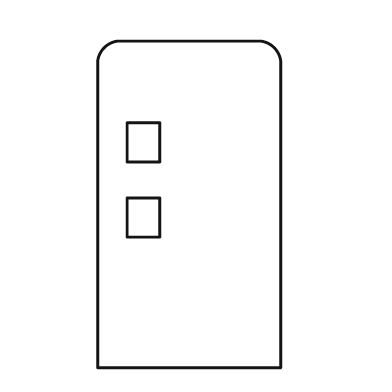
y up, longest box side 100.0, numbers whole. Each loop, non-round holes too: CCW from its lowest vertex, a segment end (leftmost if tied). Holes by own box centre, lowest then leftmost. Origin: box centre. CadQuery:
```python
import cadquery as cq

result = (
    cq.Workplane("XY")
    .moveTo(-28.0, -50.0)
    .lineTo(28.0, -50.0)
    .lineTo(28.0, 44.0)
    .threePointArc((26.0, 48.0), (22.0, 50.0))
    .lineTo(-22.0, 50.0)
    .threePointArc((-26.0, 48.0), (-28.0, 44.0))
    .close()
    .moveTo(-19.0, -10.0)
    .lineTo(-9.0, -10.0)
    .lineTo(-9.0, 2.0)
    .lineTo(-19.0, 2.0)
    .close()
    .moveTo(-19.0, 13.0)
    .lineTo(-9.0, 13.0)
    .lineTo(-9.0, 25.0)
    .lineTo(-19.0, 25.0)
    .close()
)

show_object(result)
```